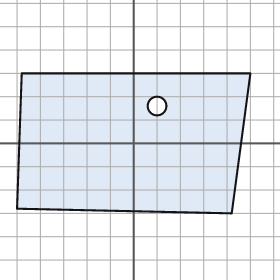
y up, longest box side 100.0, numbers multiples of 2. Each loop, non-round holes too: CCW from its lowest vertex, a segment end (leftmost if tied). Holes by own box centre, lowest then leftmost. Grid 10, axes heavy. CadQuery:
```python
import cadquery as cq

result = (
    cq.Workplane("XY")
    .moveTo(42.0, -30.0)
    .lineTo(50.0, 30.0)
    .lineTo(-48.0, 30.0)
    .lineTo(-50.0, -28.0)
    .close()
    .moveTo(10.0, 16.0)
    .circle(4.0)
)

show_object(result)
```